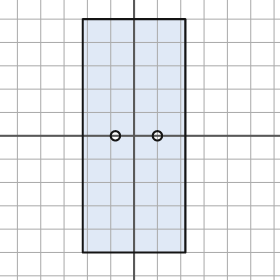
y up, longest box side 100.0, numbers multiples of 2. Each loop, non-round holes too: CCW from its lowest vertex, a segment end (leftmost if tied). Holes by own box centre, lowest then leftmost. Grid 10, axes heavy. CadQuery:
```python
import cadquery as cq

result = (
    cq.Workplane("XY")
    .moveTo(-22.0, -50.0)
    .lineTo(22.0, -50.0)
    .lineTo(22.0, 50.0)
    .lineTo(-22.0, 50.0)
    .close()
    .moveTo(-8.0, 0.0)
    .circle(2.0)
    .moveTo(10.0, 0.0)
    .circle(2.0)
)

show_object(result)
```